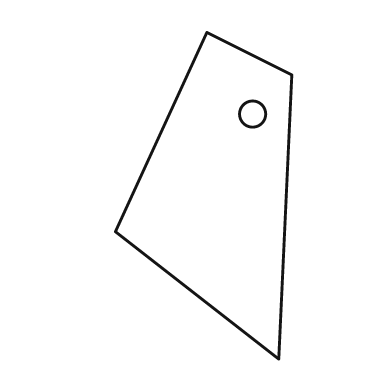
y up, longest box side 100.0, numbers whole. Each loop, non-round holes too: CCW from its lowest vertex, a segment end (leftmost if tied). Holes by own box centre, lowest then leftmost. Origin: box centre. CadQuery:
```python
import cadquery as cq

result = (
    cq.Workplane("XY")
    .moveTo(23.0, -50.0)
    .lineTo(27.0, 37.0)
    .lineTo(1.0, 50.0)
    .lineTo(-27.0, -11.0)
    .close()
    .moveTo(15.0, 25.0)
    .circle(4.0)
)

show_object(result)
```